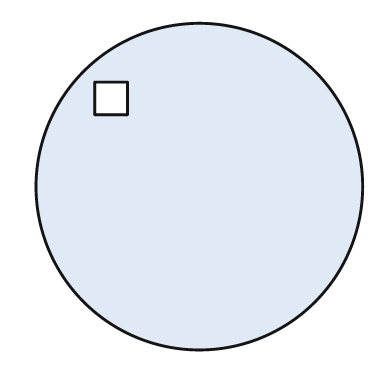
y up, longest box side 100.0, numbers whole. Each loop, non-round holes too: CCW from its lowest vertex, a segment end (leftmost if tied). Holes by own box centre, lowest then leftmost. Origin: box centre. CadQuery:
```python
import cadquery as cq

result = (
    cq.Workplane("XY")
    .moveTo(0.0, 0.0)
    .circle(50.0)
    .moveTo(-32.0, 22.0)
    .lineTo(-22.0, 22.0)
    .lineTo(-22.0, 32.0)
    .lineTo(-32.0, 32.0)
    .close()
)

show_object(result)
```